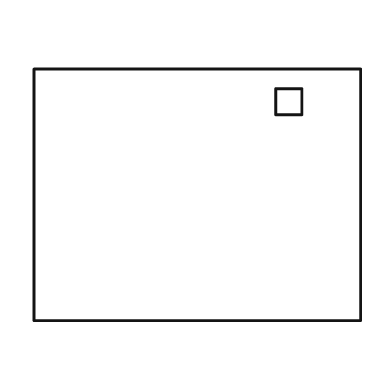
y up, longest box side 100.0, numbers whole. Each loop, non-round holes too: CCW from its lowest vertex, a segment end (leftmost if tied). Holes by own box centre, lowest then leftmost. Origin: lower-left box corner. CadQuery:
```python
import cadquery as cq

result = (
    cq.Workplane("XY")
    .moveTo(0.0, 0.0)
    .lineTo(100.0, 0.0)
    .lineTo(100.0, 77.0)
    .lineTo(0.0, 77.0)
    .close()
    .moveTo(74.0, 63.0)
    .lineTo(82.0, 63.0)
    .lineTo(82.0, 71.0)
    .lineTo(74.0, 71.0)
    .close()
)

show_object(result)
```